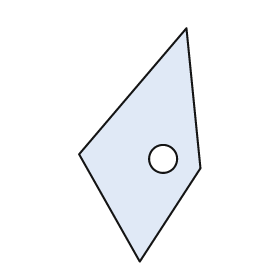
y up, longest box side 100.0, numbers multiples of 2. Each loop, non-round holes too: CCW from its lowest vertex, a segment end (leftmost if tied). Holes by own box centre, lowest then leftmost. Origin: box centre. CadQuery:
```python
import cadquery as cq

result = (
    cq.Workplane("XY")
    .moveTo(0.0, -50.0)
    .lineTo(26.0, -10.0)
    .lineTo(20.0, 50.0)
    .lineTo(-26.0, -4.0)
    .close()
    .moveTo(10.0, -6.0)
    .circle(6.0)
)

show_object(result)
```